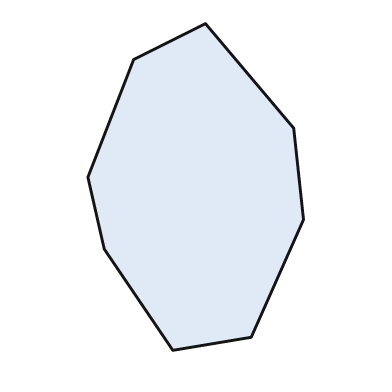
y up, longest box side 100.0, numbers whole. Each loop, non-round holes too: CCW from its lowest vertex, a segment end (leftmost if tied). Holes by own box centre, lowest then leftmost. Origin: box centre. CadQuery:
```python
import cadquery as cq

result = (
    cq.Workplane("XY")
    .moveTo(-7.0, -50.0)
    .lineTo(17.0, -46.0)
    .lineTo(33.0, -10.0)
    .lineTo(30.0, 18.0)
    .lineTo(3.0, 50.0)
    .lineTo(-19.0, 39.0)
    .lineTo(-33.0, 3.0)
    .lineTo(-28.0, -19.0)
    .close()
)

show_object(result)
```